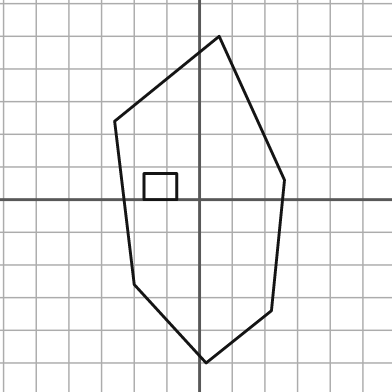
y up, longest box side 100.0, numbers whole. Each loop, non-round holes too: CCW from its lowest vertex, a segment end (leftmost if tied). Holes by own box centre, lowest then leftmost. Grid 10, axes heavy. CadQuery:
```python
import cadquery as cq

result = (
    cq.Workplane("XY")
    .moveTo(2.0, -50.0)
    .lineTo(22.0, -34.0)
    .lineTo(26.0, 6.0)
    .lineTo(6.0, 50.0)
    .lineTo(-26.0, 24.0)
    .lineTo(-20.0, -26.0)
    .close()
    .moveTo(-17.0, 0.0)
    .lineTo(-7.0, 0.0)
    .lineTo(-7.0, 8.0)
    .lineTo(-17.0, 8.0)
    .close()
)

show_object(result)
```